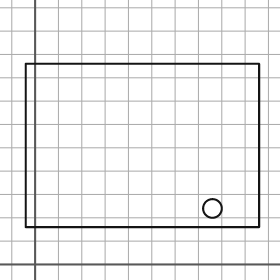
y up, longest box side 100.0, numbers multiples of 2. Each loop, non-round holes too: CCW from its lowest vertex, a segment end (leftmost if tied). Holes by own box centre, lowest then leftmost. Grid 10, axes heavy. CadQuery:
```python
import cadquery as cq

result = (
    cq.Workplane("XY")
    .moveTo(-4.0, 16.0)
    .lineTo(96.0, 16.0)
    .lineTo(96.0, 86.0)
    .lineTo(-4.0, 86.0)
    .close()
    .moveTo(76.0, 24.0)
    .circle(4.0)
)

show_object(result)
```